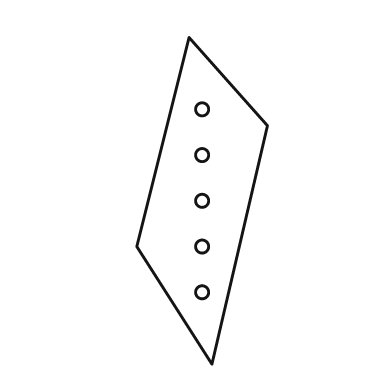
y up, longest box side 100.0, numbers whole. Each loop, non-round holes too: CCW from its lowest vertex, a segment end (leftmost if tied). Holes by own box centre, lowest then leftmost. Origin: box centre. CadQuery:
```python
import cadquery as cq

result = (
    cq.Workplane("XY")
    .moveTo(3.0, -50.0)
    .lineTo(20.0, 23.0)
    .lineTo(-4.0, 50.0)
    .lineTo(-20.0, -14.0)
    .close()
    .moveTo(0.0, -28.0)
    .circle(2.0)
    .moveTo(0.0, -14.0)
    .circle(2.0)
    .moveTo(0.0, 0.0)
    .circle(2.0)
    .moveTo(0.0, 14.0)
    .circle(2.0)
    .moveTo(0.0, 28.0)
    .circle(2.0)
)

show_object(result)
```